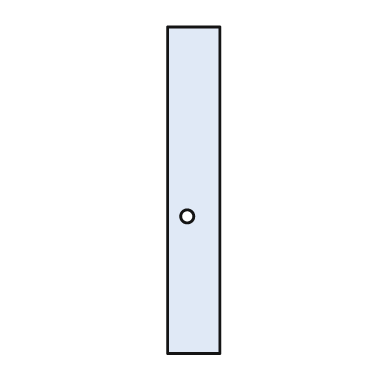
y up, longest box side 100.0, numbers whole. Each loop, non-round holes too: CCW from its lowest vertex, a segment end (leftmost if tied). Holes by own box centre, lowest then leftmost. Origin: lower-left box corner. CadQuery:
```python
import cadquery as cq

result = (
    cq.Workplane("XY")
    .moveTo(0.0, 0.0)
    .lineTo(16.0, 0.0)
    .lineTo(16.0, 100.0)
    .lineTo(0.0, 100.0)
    .close()
    .moveTo(6.0, 42.0)
    .circle(2.0)
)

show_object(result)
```